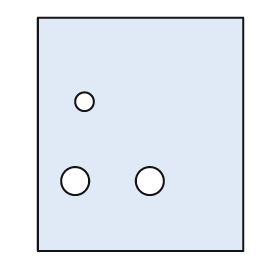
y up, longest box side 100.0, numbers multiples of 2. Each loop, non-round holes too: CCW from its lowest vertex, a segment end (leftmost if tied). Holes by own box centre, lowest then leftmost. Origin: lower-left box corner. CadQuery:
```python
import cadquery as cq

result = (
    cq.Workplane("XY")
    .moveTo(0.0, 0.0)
    .lineTo(88.0, 0.0)
    .lineTo(88.0, 100.0)
    .lineTo(0.0, 100.0)
    .close()
    .moveTo(16.0, 30.0)
    .circle(6.0)
    .moveTo(48.0, 30.0)
    .circle(6.0)
    .moveTo(20.0, 64.0)
    .circle(4.0)
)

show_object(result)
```